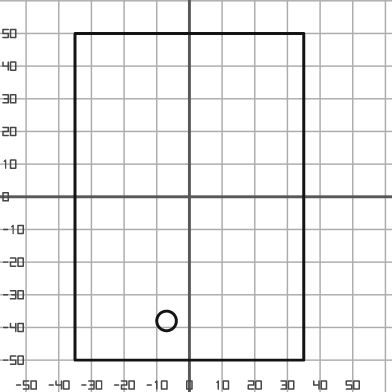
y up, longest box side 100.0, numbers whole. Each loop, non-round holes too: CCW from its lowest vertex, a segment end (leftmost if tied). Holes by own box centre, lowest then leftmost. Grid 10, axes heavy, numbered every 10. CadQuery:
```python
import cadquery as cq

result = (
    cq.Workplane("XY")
    .moveTo(-35.0, -50.0)
    .lineTo(35.0, -50.0)
    .lineTo(35.0, 50.0)
    .lineTo(-35.0, 50.0)
    .close()
    .moveTo(-7.0, -38.0)
    .circle(3.0)
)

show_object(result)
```